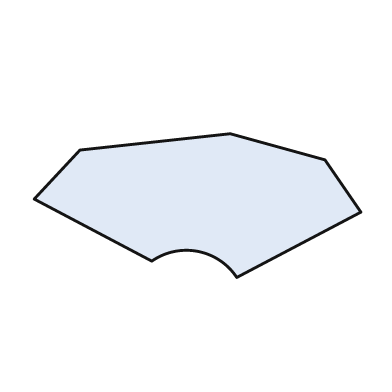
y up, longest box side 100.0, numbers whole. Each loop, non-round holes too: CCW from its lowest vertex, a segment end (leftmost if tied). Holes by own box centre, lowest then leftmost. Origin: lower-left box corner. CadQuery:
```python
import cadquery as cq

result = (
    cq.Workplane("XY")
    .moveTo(62.0, 0.0)
    .lineTo(100.0, 20.0)
    .lineTo(89.0, 36.0)
    .lineTo(60.0, 44.0)
    .lineTo(14.0, 39.0)
    .lineTo(0.0, 24.0)
    .lineTo(36.0, 5.0)
    .threePointArc((50.0, 8.0), (62.0, 0.0))
    .close()
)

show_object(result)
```